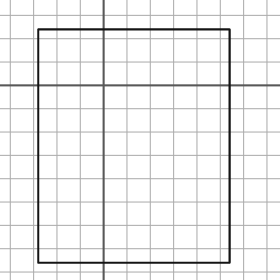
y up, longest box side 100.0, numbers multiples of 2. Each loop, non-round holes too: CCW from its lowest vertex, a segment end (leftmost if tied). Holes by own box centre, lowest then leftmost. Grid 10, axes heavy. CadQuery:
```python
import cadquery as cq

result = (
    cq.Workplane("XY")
    .moveTo(-28.0, -76.0)
    .lineTo(54.0, -76.0)
    .lineTo(54.0, 24.0)
    .lineTo(-28.0, 24.0)
    .close()
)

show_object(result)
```